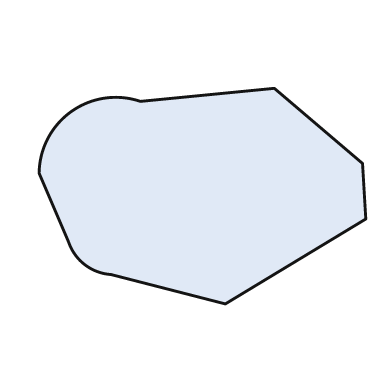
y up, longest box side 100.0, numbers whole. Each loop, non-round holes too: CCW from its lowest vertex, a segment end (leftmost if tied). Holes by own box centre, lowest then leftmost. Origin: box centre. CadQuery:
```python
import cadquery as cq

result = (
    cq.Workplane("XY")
    .moveTo(7.0, -33.0)
    .lineTo(50.0, -7.0)
    .lineTo(49.0, 10.0)
    .lineTo(22.0, 33.0)
    .lineTo(-19.0, 29.0)
    .threePointArc((-40.0, 26.0), (-50.0, 7.0))
    .lineTo(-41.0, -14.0)
    .threePointArc((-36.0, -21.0), (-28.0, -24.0))
    .close()
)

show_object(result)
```